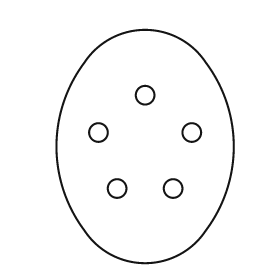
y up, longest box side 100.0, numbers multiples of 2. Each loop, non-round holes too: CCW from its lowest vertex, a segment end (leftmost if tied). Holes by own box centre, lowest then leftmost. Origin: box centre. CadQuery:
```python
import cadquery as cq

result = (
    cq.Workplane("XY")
    .moveTo(-26.0, -36.0)
    .threePointArc((0.0, -50.0), (26.0, -36.0))
    .threePointArc((38.0, 0.0), (26.0, 36.0))
    .threePointArc((0.0, 50.0), (-26.0, 36.0))
    .threePointArc((-38.0, 0.0), (-26.0, -36.0))
    .close()
    .moveTo(-12.0, -18.0)
    .circle(4.0)
    .moveTo(12.0, -18.0)
    .circle(4.0)
    .moveTo(-20.0, 6.0)
    .circle(4.0)
    .moveTo(20.0, 6.0)
    .circle(4.0)
    .moveTo(0.0, 22.0)
    .circle(4.0)
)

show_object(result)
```